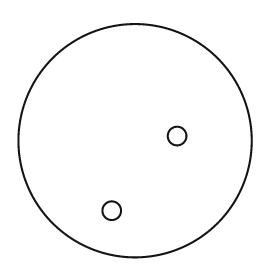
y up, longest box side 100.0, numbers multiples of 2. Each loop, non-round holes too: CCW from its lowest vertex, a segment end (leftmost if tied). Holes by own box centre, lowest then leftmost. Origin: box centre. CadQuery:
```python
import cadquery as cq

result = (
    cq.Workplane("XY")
    .moveTo(0.0, 0.0)
    .circle(50.0)
    .moveTo(-10.0, -30.0)
    .circle(4.0)
    .moveTo(18.0, 2.0)
    .circle(4.0)
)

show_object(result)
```